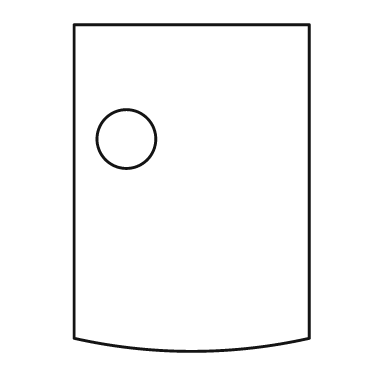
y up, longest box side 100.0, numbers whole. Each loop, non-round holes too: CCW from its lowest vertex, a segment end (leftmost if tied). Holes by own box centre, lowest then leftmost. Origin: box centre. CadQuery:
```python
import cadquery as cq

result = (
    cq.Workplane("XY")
    .moveTo(-36.0, -46.0)
    .threePointArc((0.0, -50.0), (36.0, -46.0))
    .lineTo(36.0, 50.0)
    .lineTo(-36.0, 50.0)
    .close()
    .moveTo(-20.0, 15.0)
    .circle(9.0)
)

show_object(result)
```